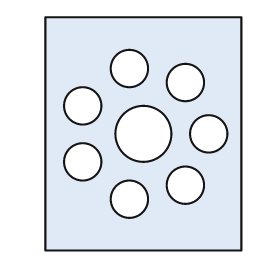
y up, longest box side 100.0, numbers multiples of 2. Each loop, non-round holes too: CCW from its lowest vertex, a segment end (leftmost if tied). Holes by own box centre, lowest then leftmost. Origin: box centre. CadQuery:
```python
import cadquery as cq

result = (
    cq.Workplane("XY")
    .moveTo(-42.0, -50.0)
    .lineTo(42.0, -50.0)
    .lineTo(42.0, 50.0)
    .lineTo(-42.0, 50.0)
    .close()
    .moveTo(-6.0, -28.0)
    .circle(8.0)
    .moveTo(18.0, -22.0)
    .circle(8.0)
    .moveTo(-26.0, -12.0)
    .circle(8.0)
    .moveTo(0.0, 0.0)
    .circle(12.0)
    .moveTo(28.0, 0.0)
    .circle(8.0)
    .moveTo(-26.0, 12.0)
    .circle(8.0)
    .moveTo(18.0, 22.0)
    .circle(8.0)
    .moveTo(-6.0, 28.0)
    .circle(8.0)
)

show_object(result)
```